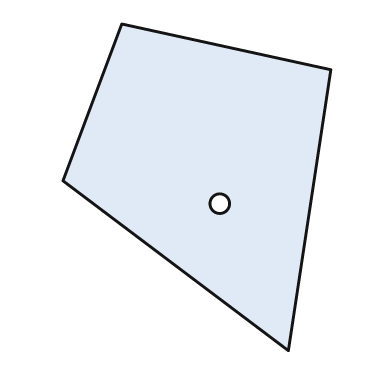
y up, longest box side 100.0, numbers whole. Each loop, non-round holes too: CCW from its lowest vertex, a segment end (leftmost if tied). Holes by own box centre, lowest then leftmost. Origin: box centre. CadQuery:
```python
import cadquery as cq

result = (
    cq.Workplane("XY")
    .moveTo(28.0, -50.0)
    .lineTo(41.0, 36.0)
    .lineTo(-23.0, 50.0)
    .lineTo(-41.0, 2.0)
    .close()
    .moveTo(7.0, -5.0)
    .circle(3.0)
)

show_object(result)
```